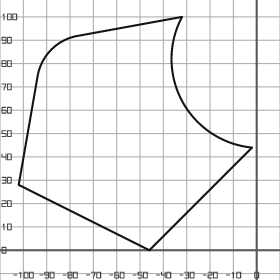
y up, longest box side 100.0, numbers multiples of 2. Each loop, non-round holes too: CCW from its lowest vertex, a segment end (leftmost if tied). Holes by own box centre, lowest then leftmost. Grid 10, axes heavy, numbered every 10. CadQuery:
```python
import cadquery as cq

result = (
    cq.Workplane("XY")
    .moveTo(-46.0, 0.0)
    .lineTo(-2.0, 44.0)
    .threePointArc((-32.0, 64.0), (-32.0, 100.0))
    .lineTo(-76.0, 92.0)
    .threePointArc((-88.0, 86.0), (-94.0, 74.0))
    .lineTo(-102.0, 28.0)
    .close()
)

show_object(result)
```